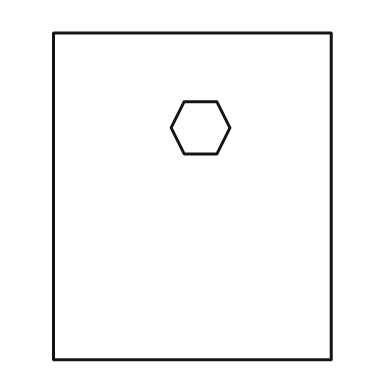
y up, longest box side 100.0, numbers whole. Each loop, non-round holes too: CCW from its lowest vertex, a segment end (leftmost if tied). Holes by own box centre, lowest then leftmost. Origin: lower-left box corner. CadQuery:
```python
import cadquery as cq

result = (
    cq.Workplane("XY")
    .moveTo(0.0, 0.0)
    .lineTo(85.0, 0.0)
    .lineTo(85.0, 100.0)
    .lineTo(0.0, 100.0)
    .close()
    .moveTo(40.0, 63.0)
    .lineTo(50.0, 63.0)
    .lineTo(54.0, 71.0)
    .lineTo(50.0, 79.0)
    .lineTo(40.0, 79.0)
    .lineTo(36.0, 71.0)
    .close()
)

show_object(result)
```